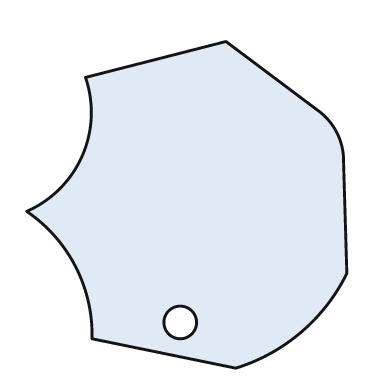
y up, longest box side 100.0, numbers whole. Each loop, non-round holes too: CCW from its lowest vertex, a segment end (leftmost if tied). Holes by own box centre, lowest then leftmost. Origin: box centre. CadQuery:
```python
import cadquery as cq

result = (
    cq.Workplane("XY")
    .moveTo(15.0, -50.0)
    .threePointArc((35.0, -39.0), (49.0, -21.0))
    .lineTo(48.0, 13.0)
    .threePointArc((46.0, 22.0), (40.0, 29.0))
    .lineTo(12.0, 50.0)
    .lineTo(-31.0, 39.0)
    .threePointArc((-32.0, 15.0), (-49.0, -2.0))
    .threePointArc((-34.0, -19.0), (-29.0, -41.0))
    .close()
    .moveTo(-2.0, -36.0)
    .circle(5.0)
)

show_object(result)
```